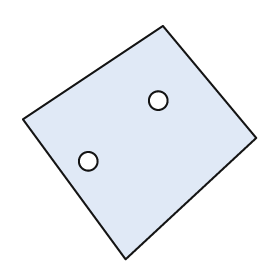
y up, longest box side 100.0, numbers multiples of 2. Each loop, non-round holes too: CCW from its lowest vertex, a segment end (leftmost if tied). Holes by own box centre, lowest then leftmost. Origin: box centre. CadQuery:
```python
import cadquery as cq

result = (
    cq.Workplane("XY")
    .moveTo(-6.0, -50.0)
    .lineTo(50.0, 2.0)
    .lineTo(10.0, 50.0)
    .lineTo(-50.0, 10.0)
    .close()
    .moveTo(-22.0, -8.0)
    .circle(4.0)
    .moveTo(8.0, 18.0)
    .circle(4.0)
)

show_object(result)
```